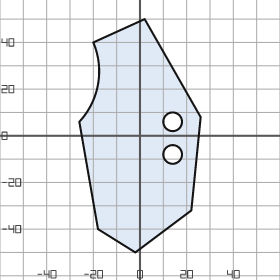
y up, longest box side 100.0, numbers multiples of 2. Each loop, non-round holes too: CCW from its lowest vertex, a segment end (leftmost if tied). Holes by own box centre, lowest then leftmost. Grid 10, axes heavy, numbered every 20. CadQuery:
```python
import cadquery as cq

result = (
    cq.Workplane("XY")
    .moveTo(-2.0, -50.0)
    .lineTo(22.0, -32.0)
    .lineTo(26.0, 8.0)
    .lineTo(2.0, 50.0)
    .lineTo(-20.0, 40.0)
    .threePointArc((-18.0, 22.0), (-26.0, 6.0))
    .lineTo(-18.0, -40.0)
    .close()
    .moveTo(14.0, -8.0)
    .circle(4.0)
    .moveTo(14.0, 6.0)
    .circle(4.0)
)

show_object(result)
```